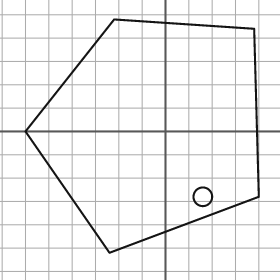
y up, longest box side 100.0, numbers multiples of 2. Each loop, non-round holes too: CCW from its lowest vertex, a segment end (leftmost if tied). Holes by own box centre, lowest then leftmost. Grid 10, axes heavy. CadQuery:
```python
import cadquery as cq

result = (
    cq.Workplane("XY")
    .moveTo(-24.0, -52.0)
    .lineTo(40.0, -28.0)
    .lineTo(38.0, 44.0)
    .lineTo(-22.0, 48.0)
    .lineTo(-60.0, 0.0)
    .close()
    .moveTo(16.0, -28.0)
    .circle(4.0)
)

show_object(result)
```